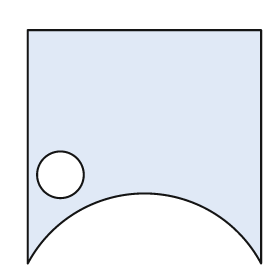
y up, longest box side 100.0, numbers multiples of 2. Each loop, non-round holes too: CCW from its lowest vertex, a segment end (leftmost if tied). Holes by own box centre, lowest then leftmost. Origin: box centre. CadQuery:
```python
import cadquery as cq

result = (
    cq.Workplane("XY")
    .moveTo(-50.0, -50.0)
    .threePointArc((0.0, -20.0), (50.0, -50.0))
    .lineTo(50.0, 50.0)
    .lineTo(-50.0, 50.0)
    .close()
    .moveTo(-36.0, -12.0)
    .circle(10.0)
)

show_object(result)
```